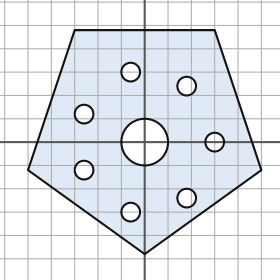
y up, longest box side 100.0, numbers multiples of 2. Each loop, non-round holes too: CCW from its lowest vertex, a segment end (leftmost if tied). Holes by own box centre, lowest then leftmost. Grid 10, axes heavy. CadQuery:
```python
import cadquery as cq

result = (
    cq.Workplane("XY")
    .moveTo(0.0, -48.0)
    .lineTo(50.0, -12.0)
    .lineTo(30.0, 48.0)
    .lineTo(-30.0, 48.0)
    .lineTo(-50.0, -12.0)
    .close()
    .moveTo(-6.0, -30.0)
    .circle(4.0)
    .moveTo(18.0, -24.0)
    .circle(4.0)
    .moveTo(-26.0, -12.0)
    .circle(4.0)
    .moveTo(0.0, 0.0)
    .circle(10.0)
    .moveTo(30.0, 0.0)
    .circle(4.0)
    .moveTo(-26.0, 12.0)
    .circle(4.0)
    .moveTo(18.0, 24.0)
    .circle(4.0)
    .moveTo(-6.0, 30.0)
    .circle(4.0)
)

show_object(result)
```